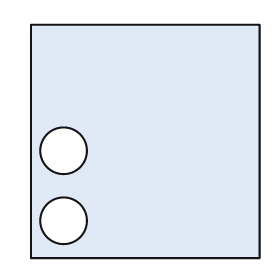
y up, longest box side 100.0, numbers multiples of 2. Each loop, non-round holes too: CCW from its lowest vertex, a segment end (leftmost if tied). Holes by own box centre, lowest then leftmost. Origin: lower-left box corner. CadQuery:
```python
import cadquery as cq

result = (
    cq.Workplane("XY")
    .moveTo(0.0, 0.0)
    .lineTo(98.0, 0.0)
    .lineTo(98.0, 100.0)
    .lineTo(0.0, 100.0)
    .close()
    .moveTo(14.0, 16.0)
    .circle(10.0)
    .moveTo(14.0, 46.0)
    .circle(10.0)
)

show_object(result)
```